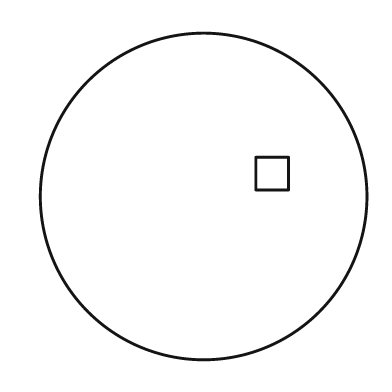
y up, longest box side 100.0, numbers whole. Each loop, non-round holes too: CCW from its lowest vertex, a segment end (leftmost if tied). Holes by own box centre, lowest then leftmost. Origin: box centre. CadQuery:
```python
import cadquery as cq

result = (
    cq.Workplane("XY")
    .moveTo(0.0, 0.0)
    .circle(50.0)
    .moveTo(16.0, 2.0)
    .lineTo(26.0, 2.0)
    .lineTo(26.0, 12.0)
    .lineTo(16.0, 12.0)
    .close()
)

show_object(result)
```